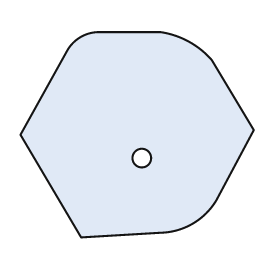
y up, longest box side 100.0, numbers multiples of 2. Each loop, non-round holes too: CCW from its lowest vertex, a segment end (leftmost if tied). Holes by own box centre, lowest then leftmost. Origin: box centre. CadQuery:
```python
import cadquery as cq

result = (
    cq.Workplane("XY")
    .moveTo(-24.0, -44.0)
    .lineTo(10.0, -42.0)
    .threePointArc((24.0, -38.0), (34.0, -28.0))
    .lineTo(50.0, 2.0)
    .lineTo(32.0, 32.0)
    .threePointArc((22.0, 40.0), (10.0, 44.0))
    .lineTo(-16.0, 44.0)
    .threePointArc((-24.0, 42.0), (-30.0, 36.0))
    .lineTo(-50.0, 0.0)
    .close()
    .moveTo(2.0, -10.0)
    .circle(4.0)
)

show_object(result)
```